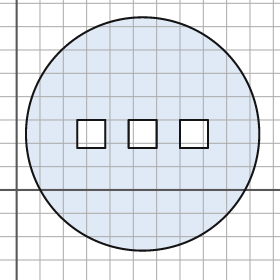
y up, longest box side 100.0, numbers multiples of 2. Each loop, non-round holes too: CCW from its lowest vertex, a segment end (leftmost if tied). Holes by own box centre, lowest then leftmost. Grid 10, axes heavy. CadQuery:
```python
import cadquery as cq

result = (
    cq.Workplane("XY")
    .moveTo(54.0, 24.0)
    .circle(50.0)
    .moveTo(26.0, 18.0)
    .lineTo(38.0, 18.0)
    .lineTo(38.0, 30.0)
    .lineTo(26.0, 30.0)
    .close()
    .moveTo(48.0, 18.0)
    .lineTo(60.0, 18.0)
    .lineTo(60.0, 30.0)
    .lineTo(48.0, 30.0)
    .close()
    .moveTo(70.0, 18.0)
    .lineTo(82.0, 18.0)
    .lineTo(82.0, 30.0)
    .lineTo(70.0, 30.0)
    .close()
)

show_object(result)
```